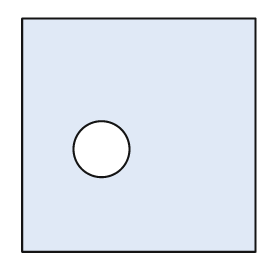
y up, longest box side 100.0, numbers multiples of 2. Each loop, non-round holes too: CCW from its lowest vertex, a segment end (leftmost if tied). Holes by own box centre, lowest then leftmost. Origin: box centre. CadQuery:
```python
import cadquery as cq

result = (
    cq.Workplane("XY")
    .moveTo(-50.0, -50.0)
    .lineTo(50.0, -50.0)
    .lineTo(50.0, 50.0)
    .lineTo(-50.0, 50.0)
    .close()
    .moveTo(-16.0, -6.0)
    .circle(12.0)
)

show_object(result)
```